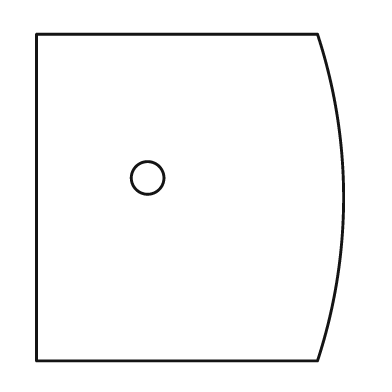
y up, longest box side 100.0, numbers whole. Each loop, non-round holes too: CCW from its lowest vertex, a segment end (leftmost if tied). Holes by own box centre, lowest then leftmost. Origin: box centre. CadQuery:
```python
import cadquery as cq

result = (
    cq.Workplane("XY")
    .moveTo(-47.0, -50.0)
    .lineTo(39.0, -50.0)
    .threePointArc((47.0, 0.0), (39.0, 50.0))
    .lineTo(-47.0, 50.0)
    .close()
    .moveTo(-13.0, 6.0)
    .circle(5.0)
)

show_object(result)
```